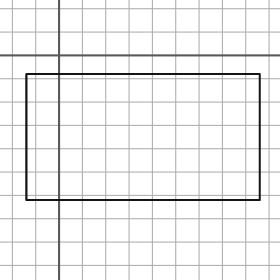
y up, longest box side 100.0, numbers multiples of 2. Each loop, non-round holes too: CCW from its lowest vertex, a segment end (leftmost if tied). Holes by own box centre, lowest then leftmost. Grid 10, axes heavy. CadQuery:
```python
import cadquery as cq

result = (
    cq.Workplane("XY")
    .moveTo(-14.0, -62.0)
    .lineTo(86.0, -62.0)
    .lineTo(86.0, -8.0)
    .lineTo(-14.0, -8.0)
    .close()
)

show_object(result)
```